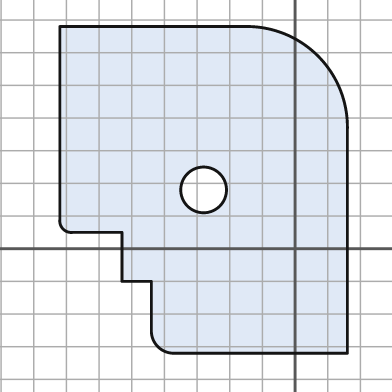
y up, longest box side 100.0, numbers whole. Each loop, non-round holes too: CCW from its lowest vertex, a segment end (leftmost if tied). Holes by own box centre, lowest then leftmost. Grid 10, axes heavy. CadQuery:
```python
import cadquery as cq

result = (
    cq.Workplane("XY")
    .moveTo(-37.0, -32.0)
    .lineTo(16.0, -32.0)
    .lineTo(16.0, 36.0)
    .threePointArc((7.0, 59.0), (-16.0, 68.0))
    .lineTo(-72.0, 68.0)
    .lineTo(-72.0, 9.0)
    .threePointArc((-71.0, 6.0), (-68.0, 5.0))
    .lineTo(-53.0, 5.0)
    .lineTo(-53.0, -10.0)
    .lineTo(-44.0, -10.0)
    .lineTo(-44.0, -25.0)
    .threePointArc((-42.0, -30.0), (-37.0, -32.0))
    .close()
    .moveTo(-28.0, 18.0)
    .circle(7.0)
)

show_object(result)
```